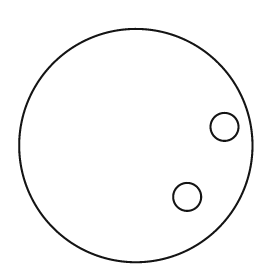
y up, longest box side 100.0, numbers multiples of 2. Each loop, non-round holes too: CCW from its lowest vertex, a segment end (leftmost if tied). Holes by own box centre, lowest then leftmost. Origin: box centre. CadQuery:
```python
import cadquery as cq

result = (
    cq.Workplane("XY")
    .moveTo(0.0, 0.0)
    .circle(50.0)
    .moveTo(22.0, -22.0)
    .circle(6.0)
    .moveTo(38.0, 8.0)
    .circle(6.0)
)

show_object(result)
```